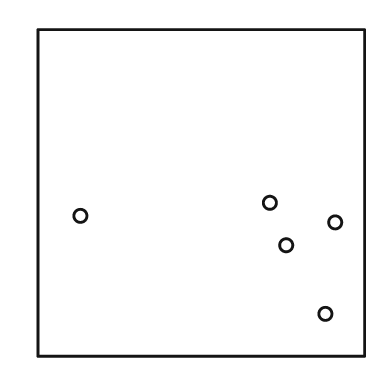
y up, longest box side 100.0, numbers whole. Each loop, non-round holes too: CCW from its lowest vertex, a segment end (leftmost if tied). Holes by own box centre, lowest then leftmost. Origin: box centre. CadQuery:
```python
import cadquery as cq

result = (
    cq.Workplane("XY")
    .moveTo(-50.0, -50.0)
    .lineTo(50.0, -50.0)
    .lineTo(50.0, 50.0)
    .lineTo(-50.0, 50.0)
    .close()
    .moveTo(38.0, -37.0)
    .circle(2.0)
    .moveTo(26.0, -16.0)
    .circle(2.0)
    .moveTo(41.0, -9.0)
    .circle(2.0)
    .moveTo(-37.0, -7.0)
    .circle(2.0)
    .moveTo(21.0, -3.0)
    .circle(2.0)
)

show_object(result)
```